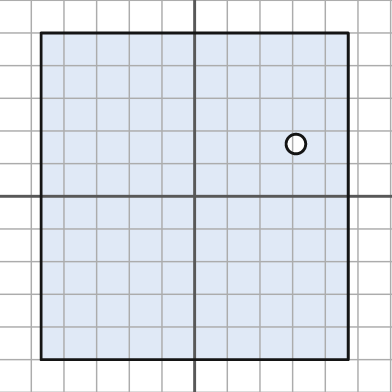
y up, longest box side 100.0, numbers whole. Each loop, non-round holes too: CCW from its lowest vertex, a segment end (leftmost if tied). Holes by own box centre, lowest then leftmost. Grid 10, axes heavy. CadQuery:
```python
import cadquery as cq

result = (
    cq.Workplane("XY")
    .moveTo(-47.0, -50.0)
    .lineTo(47.0, -50.0)
    .lineTo(47.0, 50.0)
    .lineTo(-47.0, 50.0)
    .close()
    .moveTo(31.0, 16.0)
    .circle(3.0)
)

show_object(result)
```